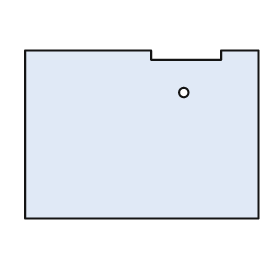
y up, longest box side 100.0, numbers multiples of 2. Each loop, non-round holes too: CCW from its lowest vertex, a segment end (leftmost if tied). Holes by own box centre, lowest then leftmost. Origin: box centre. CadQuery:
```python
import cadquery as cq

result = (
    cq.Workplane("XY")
    .moveTo(-50.0, -36.0)
    .lineTo(50.0, -36.0)
    .lineTo(50.0, 36.0)
    .lineTo(34.0, 36.0)
    .lineTo(34.0, 32.0)
    .lineTo(4.0, 32.0)
    .lineTo(4.0, 36.0)
    .lineTo(-50.0, 36.0)
    .close()
    .moveTo(18.0, 18.0)
    .circle(2.0)
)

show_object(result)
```